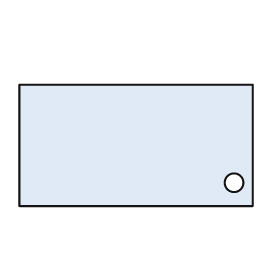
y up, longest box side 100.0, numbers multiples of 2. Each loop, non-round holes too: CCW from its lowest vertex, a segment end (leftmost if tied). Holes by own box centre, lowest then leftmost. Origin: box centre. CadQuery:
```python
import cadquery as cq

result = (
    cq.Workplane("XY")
    .moveTo(-50.0, -26.0)
    .lineTo(50.0, -26.0)
    .lineTo(50.0, 26.0)
    .lineTo(-50.0, 26.0)
    .close()
    .moveTo(42.0, -16.0)
    .circle(4.0)
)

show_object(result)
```